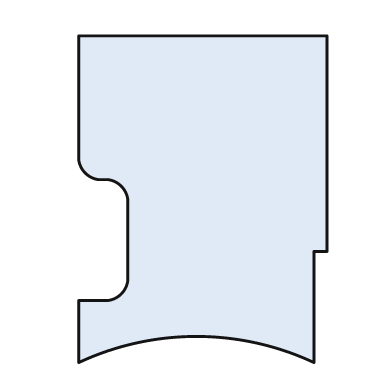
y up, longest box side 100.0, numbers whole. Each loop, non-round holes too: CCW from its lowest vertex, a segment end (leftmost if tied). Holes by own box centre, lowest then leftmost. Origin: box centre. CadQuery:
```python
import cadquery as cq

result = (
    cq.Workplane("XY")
    .moveTo(-38.0, -50.0)
    .threePointArc((-2.0, -42.0), (34.0, -50.0))
    .lineTo(34.0, -16.0)
    .lineTo(38.0, -16.0)
    .lineTo(38.0, 50.0)
    .lineTo(-38.0, 50.0)
    .lineTo(-38.0, 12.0)
    .threePointArc((-36.0, 8.0), (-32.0, 6.0))
    .lineTo(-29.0, 6.0)
    .threePointArc((-25.0, 4.0), (-23.0, 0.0))
    .lineTo(-23.0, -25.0)
    .threePointArc((-25.0, -29.0), (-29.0, -31.0))
    .lineTo(-38.0, -31.0)
    .close()
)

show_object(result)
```